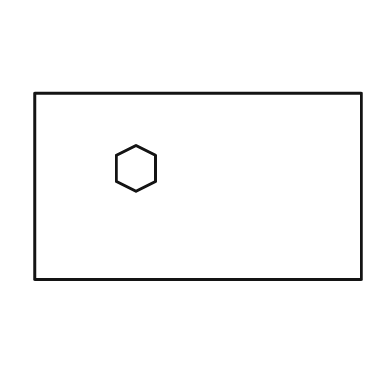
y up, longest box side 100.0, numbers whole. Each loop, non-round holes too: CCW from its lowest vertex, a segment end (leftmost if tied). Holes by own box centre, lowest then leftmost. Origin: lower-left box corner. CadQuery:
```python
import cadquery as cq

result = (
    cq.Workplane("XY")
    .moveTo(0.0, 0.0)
    .lineTo(100.0, 0.0)
    .lineTo(100.0, 57.0)
    .lineTo(0.0, 57.0)
    .close()
    .moveTo(31.0, 27.0)
    .lineTo(37.0, 30.0)
    .lineTo(37.0, 38.0)
    .lineTo(31.0, 41.0)
    .lineTo(25.0, 38.0)
    .lineTo(25.0, 30.0)
    .close()
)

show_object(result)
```